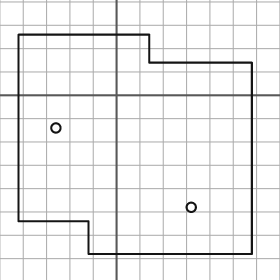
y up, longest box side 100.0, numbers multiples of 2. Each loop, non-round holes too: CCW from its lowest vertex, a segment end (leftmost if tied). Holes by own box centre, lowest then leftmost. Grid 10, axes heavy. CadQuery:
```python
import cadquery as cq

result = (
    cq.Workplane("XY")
    .moveTo(-12.0, -68.0)
    .lineTo(58.0, -68.0)
    .lineTo(58.0, 14.0)
    .lineTo(14.0, 14.0)
    .lineTo(14.0, 26.0)
    .lineTo(-42.0, 26.0)
    .lineTo(-42.0, -54.0)
    .lineTo(-12.0, -54.0)
    .close()
    .moveTo(32.0, -48.0)
    .circle(2.0)
    .moveTo(-26.0, -14.0)
    .circle(2.0)
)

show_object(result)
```